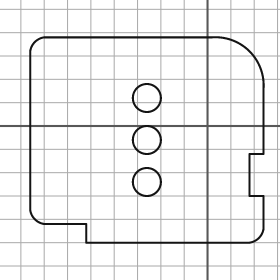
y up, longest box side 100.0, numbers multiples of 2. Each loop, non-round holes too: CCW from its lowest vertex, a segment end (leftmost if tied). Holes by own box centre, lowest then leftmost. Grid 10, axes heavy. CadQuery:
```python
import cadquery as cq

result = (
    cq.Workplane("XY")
    .moveTo(-52.0, -50.0)
    .lineTo(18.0, -50.0)
    .threePointArc((22.0, -48.0), (24.0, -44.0))
    .lineTo(24.0, -30.0)
    .lineTo(18.0, -30.0)
    .lineTo(18.0, -12.0)
    .lineTo(24.0, -12.0)
    .lineTo(24.0, 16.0)
    .threePointArc((18.0, 32.0), (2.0, 38.0))
    .lineTo(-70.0, 38.0)
    .threePointArc((-74.0, 36.0), (-76.0, 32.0))
    .lineTo(-76.0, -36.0)
    .threePointArc((-74.0, -40.0), (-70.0, -42.0))
    .lineTo(-52.0, -42.0)
    .close()
    .moveTo(-26.0, -24.0)
    .circle(6.0)
    .moveTo(-26.0, -6.0)
    .circle(6.0)
    .moveTo(-26.0, 12.0)
    .circle(6.0)
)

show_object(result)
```